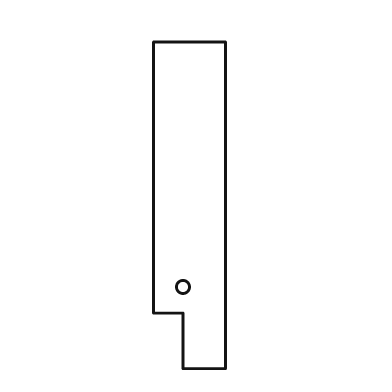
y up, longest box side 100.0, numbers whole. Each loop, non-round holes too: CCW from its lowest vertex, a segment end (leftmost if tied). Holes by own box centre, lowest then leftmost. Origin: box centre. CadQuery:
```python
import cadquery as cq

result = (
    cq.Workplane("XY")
    .moveTo(-2.0, -50.0)
    .lineTo(11.0, -50.0)
    .lineTo(11.0, 50.0)
    .lineTo(-11.0, 50.0)
    .lineTo(-11.0, -33.0)
    .lineTo(-2.0, -33.0)
    .close()
    .moveTo(-2.0, -25.0)
    .circle(2.0)
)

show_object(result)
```